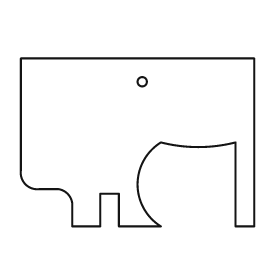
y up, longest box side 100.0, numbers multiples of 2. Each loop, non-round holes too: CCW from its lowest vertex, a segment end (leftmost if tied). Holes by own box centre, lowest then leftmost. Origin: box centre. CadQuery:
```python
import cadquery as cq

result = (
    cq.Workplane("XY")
    .moveTo(-28.0, -36.0)
    .lineTo(-16.0, -36.0)
    .lineTo(-16.0, -22.0)
    .lineTo(-8.0, -22.0)
    .lineTo(-8.0, -36.0)
    .lineTo(10.0, -36.0)
    .threePointArc((0.0, -18.0), (10.0, 0.0))
    .threePointArc((26.0, -2.0), (42.0, 0.0))
    .lineTo(42.0, -36.0)
    .lineTo(50.0, -36.0)
    .lineTo(50.0, 36.0)
    .lineTo(-50.0, 36.0)
    .lineTo(-50.0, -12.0)
    .threePointArc((-48.0, -18.0), (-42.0, -20.0))
    .lineTo(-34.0, -20.0)
    .threePointArc((-30.0, -22.0), (-28.0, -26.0))
    .close()
    .moveTo(2.0, 26.0)
    .circle(2.0)
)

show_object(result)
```